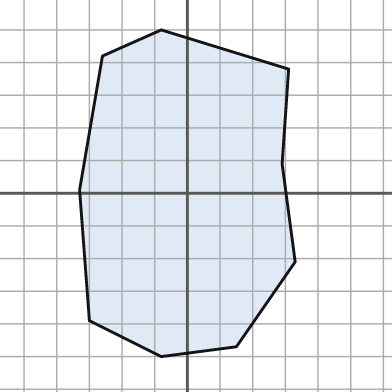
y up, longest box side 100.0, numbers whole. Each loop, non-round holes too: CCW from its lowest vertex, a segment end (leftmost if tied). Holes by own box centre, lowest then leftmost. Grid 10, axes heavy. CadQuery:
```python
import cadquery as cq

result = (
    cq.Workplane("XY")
    .moveTo(-8.0, -50.0)
    .lineTo(15.0, -47.0)
    .lineTo(33.0, -21.0)
    .lineTo(29.0, 9.0)
    .lineTo(31.0, 38.0)
    .lineTo(-8.0, 50.0)
    .lineTo(-26.0, 42.0)
    .lineTo(-33.0, 1.0)
    .lineTo(-30.0, -39.0)
    .close()
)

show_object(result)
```